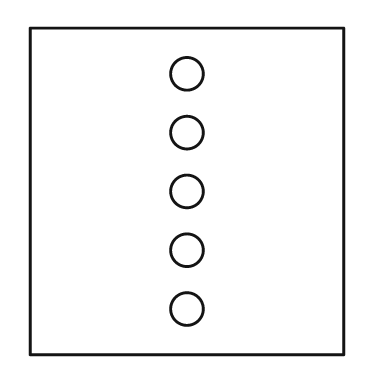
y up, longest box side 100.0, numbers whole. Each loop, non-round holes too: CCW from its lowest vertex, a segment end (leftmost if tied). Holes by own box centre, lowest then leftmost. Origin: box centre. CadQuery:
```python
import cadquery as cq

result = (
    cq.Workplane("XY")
    .moveTo(-48.0, -50.0)
    .lineTo(48.0, -50.0)
    .lineTo(48.0, 50.0)
    .lineTo(-48.0, 50.0)
    .close()
    .moveTo(0.0, -36.0)
    .circle(5.0)
    .moveTo(0.0, -18.0)
    .circle(5.0)
    .moveTo(0.0, 0.0)
    .circle(5.0)
    .moveTo(0.0, 18.0)
    .circle(5.0)
    .moveTo(0.0, 36.0)
    .circle(5.0)
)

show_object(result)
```